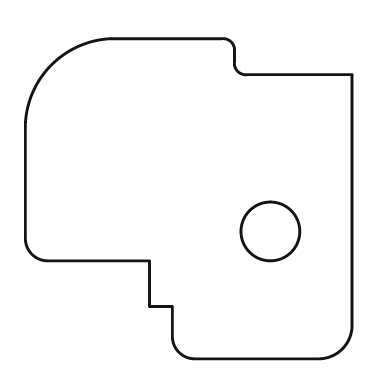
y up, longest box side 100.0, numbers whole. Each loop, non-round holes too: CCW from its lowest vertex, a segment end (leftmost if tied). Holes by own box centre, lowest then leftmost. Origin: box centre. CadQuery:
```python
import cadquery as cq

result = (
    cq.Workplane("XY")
    .moveTo(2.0, -49.0)
    .lineTo(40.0, -49.0)
    .threePointArc((47.0, -46.0), (50.0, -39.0))
    .lineTo(50.0, 38.0)
    .lineTo(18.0, 38.0)
    .threePointArc((15.0, 39.0), (14.0, 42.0))
    .lineTo(14.0, 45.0)
    .threePointArc((13.0, 48.0), (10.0, 49.0))
    .lineTo(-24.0, 49.0)
    .threePointArc((-42.0, 41.0), (-50.0, 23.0))
    .lineTo(-50.0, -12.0)
    .threePointArc((-48.0, -17.0), (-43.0, -19.0))
    .lineTo(-12.0, -19.0)
    .lineTo(-12.0, -33.0)
    .lineTo(-5.0, -33.0)
    .lineTo(-5.0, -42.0)
    .threePointArc((-3.0, -47.0), (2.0, -49.0))
    .close()
    .moveTo(25.0, -10.0)
    .circle(9.0)
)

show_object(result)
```